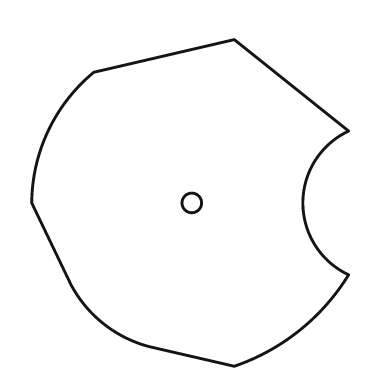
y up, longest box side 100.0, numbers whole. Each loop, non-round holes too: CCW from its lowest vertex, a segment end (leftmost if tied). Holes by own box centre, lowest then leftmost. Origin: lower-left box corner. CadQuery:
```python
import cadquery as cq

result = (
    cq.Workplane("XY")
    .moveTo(62.0, 0.0)
    .threePointArc((82.0, 11.0), (97.0, 28.0))
    .threePointArc((83.0, 50.0), (97.0, 72.0))
    .lineTo(62.0, 100.0)
    .lineTo(19.0, 90.0)
    .threePointArc((5.0, 72.0), (0.0, 50.0))
    .lineTo(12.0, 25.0)
    .threePointArc((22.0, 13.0), (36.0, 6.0))
    .close()
    .moveTo(49.0, 50.0)
    .circle(3.0)
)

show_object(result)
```